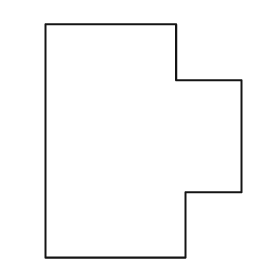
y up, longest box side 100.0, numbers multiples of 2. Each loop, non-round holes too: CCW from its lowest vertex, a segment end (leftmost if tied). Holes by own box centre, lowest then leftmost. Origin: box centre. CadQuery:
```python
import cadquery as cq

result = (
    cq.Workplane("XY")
    .moveTo(-42.0, -50.0)
    .lineTo(18.0, -50.0)
    .lineTo(18.0, -22.0)
    .lineTo(42.0, -22.0)
    .lineTo(42.0, 26.0)
    .lineTo(14.0, 26.0)
    .lineTo(14.0, 50.0)
    .lineTo(-42.0, 50.0)
    .close()
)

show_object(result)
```